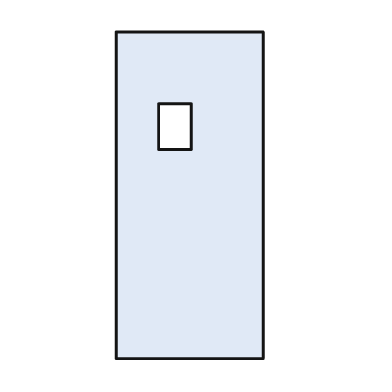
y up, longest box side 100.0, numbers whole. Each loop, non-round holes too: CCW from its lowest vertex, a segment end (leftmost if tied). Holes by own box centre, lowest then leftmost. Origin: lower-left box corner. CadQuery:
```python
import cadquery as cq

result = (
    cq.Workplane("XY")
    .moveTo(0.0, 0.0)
    .lineTo(45.0, 0.0)
    .lineTo(45.0, 100.0)
    .lineTo(0.0, 100.0)
    .close()
    .moveTo(13.0, 64.0)
    .lineTo(23.0, 64.0)
    .lineTo(23.0, 78.0)
    .lineTo(13.0, 78.0)
    .close()
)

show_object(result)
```